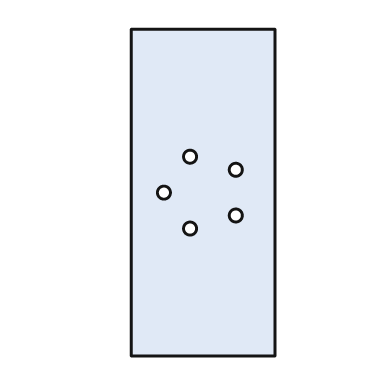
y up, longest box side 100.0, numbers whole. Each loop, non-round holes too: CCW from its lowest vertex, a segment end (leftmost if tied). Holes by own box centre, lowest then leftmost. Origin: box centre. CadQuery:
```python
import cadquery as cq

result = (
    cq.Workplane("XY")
    .moveTo(-22.0, -50.0)
    .lineTo(22.0, -50.0)
    .lineTo(22.0, 50.0)
    .lineTo(-22.0, 50.0)
    .close()
    .moveTo(-4.0, -11.0)
    .circle(2.0)
    .moveTo(10.0, -7.0)
    .circle(2.0)
    .moveTo(-12.0, 0.0)
    .circle(2.0)
    .moveTo(10.0, 7.0)
    .circle(2.0)
    .moveTo(-4.0, 11.0)
    .circle(2.0)
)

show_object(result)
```